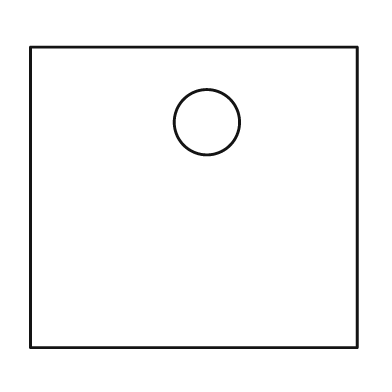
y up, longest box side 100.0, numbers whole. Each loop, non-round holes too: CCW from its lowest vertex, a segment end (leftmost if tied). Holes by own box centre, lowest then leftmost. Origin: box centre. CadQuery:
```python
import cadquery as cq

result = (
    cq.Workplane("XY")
    .moveTo(-50.0, -46.0)
    .lineTo(50.0, -46.0)
    .lineTo(50.0, 46.0)
    .lineTo(-50.0, 46.0)
    .close()
    .moveTo(4.0, 23.0)
    .circle(10.0)
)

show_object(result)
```